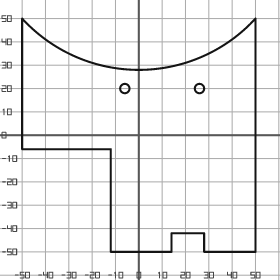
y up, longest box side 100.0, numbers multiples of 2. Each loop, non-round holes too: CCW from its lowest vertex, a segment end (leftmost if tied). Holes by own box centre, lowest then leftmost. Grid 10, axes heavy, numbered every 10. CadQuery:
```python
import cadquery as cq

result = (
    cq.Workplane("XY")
    .moveTo(-12.0, -50.0)
    .lineTo(14.0, -50.0)
    .lineTo(14.0, -42.0)
    .lineTo(28.0, -42.0)
    .lineTo(28.0, -50.0)
    .lineTo(50.0, -50.0)
    .lineTo(50.0, 50.0)
    .threePointArc((0.0, 28.0), (-50.0, 50.0))
    .lineTo(-50.0, -6.0)
    .lineTo(-12.0, -6.0)
    .close()
    .moveTo(-6.0, 20.0)
    .circle(2.0)
    .moveTo(26.0, 20.0)
    .circle(2.0)
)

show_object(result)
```